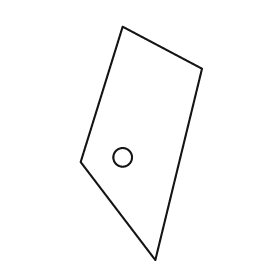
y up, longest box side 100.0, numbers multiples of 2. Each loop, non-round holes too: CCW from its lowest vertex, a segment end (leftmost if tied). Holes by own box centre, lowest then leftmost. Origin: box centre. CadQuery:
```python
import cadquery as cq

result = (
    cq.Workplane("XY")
    .moveTo(6.0, -50.0)
    .lineTo(26.0, 32.0)
    .lineTo(-8.0, 50.0)
    .lineTo(-26.0, -8.0)
    .close()
    .moveTo(-8.0, -6.0)
    .circle(4.0)
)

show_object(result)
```